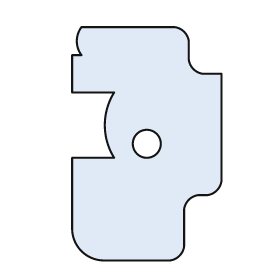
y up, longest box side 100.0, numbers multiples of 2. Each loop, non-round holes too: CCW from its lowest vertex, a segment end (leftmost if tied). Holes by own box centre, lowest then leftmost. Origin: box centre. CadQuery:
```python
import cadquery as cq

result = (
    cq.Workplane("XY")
    .moveTo(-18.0, -50.0)
    .lineTo(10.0, -50.0)
    .threePointArc((14.0, -48.0), (16.0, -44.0))
    .lineTo(16.0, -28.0)
    .threePointArc((18.0, -24.0), (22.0, -22.0))
    .lineTo(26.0, -22.0)
    .threePointArc((30.0, -20.0), (32.0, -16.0))
    .lineTo(32.0, 30.0)
    .lineTo(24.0, 30.0)
    .threePointArc((20.0, 32.0), (18.0, 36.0))
    .lineTo(18.0, 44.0)
    .threePointArc((16.0, 48.0), (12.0, 50.0))
    .lineTo(-28.0, 50.0)
    .threePointArc((-30.0, 44.0), (-28.0, 38.0))
    .lineTo(-32.0, 38.0)
    .lineTo(-32.0, 22.0)
    .lineTo(-14.0, 22.0)
    .threePointArc((-18.0, 8.0), (-14.0, -6.0))
    .lineTo(-32.0, -6.0)
    .lineTo(-32.0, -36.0)
    .threePointArc((-28.0, -46.0), (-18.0, -50.0))
    .close()
    .moveTo(0.0, 0.0)
    .circle(6.0)
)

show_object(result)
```